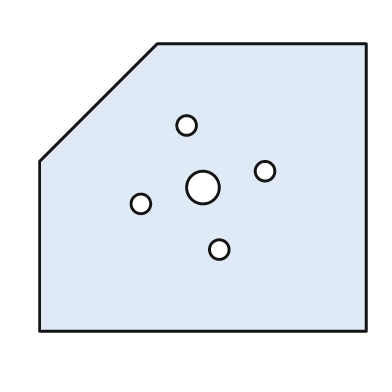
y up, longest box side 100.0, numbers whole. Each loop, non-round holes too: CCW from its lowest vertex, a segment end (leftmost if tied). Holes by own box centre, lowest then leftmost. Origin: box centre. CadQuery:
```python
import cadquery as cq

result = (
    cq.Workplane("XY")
    .moveTo(-50.0, -44.0)
    .lineTo(50.0, -44.0)
    .lineTo(50.0, 44.0)
    .lineTo(-14.0, 44.0)
    .lineTo(-50.0, 8.0)
    .close()
    .moveTo(5.0, -19.0)
    .circle(3.0)
    .moveTo(-19.0, -5.0)
    .circle(3.0)
    .moveTo(0.0, 0.0)
    .circle(5.0)
    .moveTo(19.0, 5.0)
    .circle(3.0)
    .moveTo(-5.0, 19.0)
    .circle(3.0)
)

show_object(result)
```